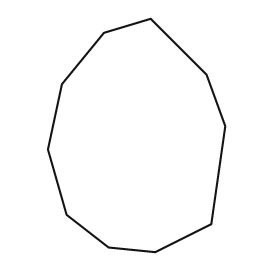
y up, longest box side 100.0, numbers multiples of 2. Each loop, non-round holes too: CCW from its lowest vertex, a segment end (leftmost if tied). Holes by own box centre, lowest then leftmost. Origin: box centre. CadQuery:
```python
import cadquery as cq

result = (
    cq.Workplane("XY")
    .moveTo(8.0, -50.0)
    .lineTo(32.0, -38.0)
    .lineTo(38.0, 4.0)
    .lineTo(30.0, 26.0)
    .lineTo(6.0, 50.0)
    .lineTo(-14.0, 44.0)
    .lineTo(-32.0, 22.0)
    .lineTo(-38.0, -6.0)
    .lineTo(-30.0, -34.0)
    .lineTo(-12.0, -48.0)
    .close()
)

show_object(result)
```